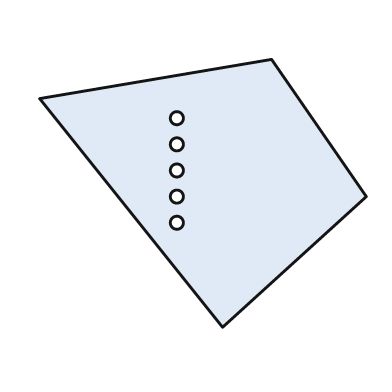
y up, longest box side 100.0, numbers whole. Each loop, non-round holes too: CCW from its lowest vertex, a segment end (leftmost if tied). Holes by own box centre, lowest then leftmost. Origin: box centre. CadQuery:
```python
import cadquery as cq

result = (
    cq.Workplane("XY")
    .moveTo(6.0, -41.0)
    .lineTo(50.0, -1.0)
    .lineTo(21.0, 41.0)
    .lineTo(-50.0, 29.0)
    .close()
    .moveTo(-8.0, -9.0)
    .circle(2.0)
    .moveTo(-8.0, -1.0)
    .circle(2.0)
    .moveTo(-8.0, 7.0)
    .circle(2.0)
    .moveTo(-8.0, 15.0)
    .circle(2.0)
    .moveTo(-8.0, 23.0)
    .circle(2.0)
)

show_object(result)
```